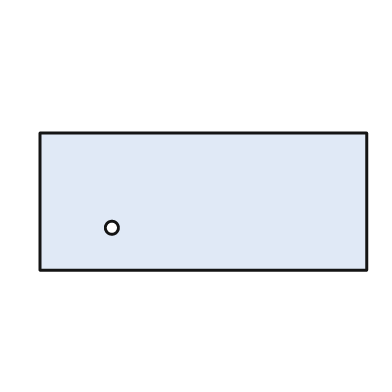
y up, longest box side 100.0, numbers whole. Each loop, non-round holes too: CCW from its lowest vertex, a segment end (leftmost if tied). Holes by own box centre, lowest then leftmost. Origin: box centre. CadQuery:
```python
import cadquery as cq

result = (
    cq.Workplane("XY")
    .moveTo(-50.0, -21.0)
    .lineTo(50.0, -21.0)
    .lineTo(50.0, 21.0)
    .lineTo(-50.0, 21.0)
    .close()
    .moveTo(-28.0, -8.0)
    .circle(2.0)
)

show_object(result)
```